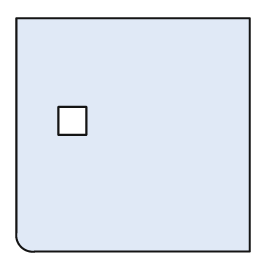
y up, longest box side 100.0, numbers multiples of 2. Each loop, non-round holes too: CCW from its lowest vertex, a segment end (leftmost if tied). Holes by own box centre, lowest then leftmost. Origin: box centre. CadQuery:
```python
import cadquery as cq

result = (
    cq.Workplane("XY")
    .moveTo(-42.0, -50.0)
    .lineTo(50.0, -50.0)
    .lineTo(50.0, 50.0)
    .lineTo(-50.0, 50.0)
    .lineTo(-50.0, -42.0)
    .threePointArc((-48.0, -48.0), (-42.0, -50.0))
    .close()
    .moveTo(-32.0, 0.0)
    .lineTo(-20.0, 0.0)
    .lineTo(-20.0, 12.0)
    .lineTo(-32.0, 12.0)
    .close()
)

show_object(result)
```